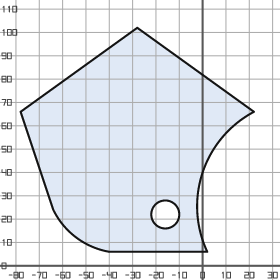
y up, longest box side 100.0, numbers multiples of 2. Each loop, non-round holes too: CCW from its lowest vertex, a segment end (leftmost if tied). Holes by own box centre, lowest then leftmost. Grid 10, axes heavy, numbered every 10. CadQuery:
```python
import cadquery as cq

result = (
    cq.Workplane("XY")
    .moveTo(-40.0, 6.0)
    .lineTo(2.0, 6.0)
    .threePointArc((0.0, 40.0), (22.0, 66.0))
    .lineTo(-28.0, 102.0)
    .lineTo(-78.0, 66.0)
    .lineTo(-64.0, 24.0)
    .threePointArc((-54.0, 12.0), (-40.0, 6.0))
    .close()
    .moveTo(-16.0, 22.0)
    .circle(6.0)
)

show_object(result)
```